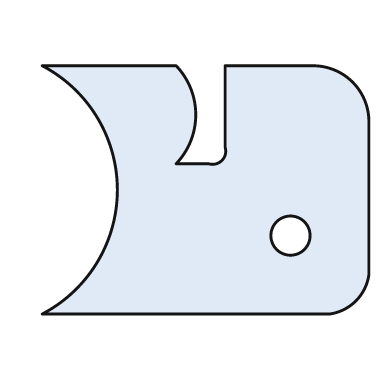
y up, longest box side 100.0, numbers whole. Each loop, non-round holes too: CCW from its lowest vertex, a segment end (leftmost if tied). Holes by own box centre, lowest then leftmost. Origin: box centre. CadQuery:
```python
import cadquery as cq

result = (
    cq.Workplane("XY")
    .moveTo(-50.0, -38.0)
    .lineTo(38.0, -38.0)
    .threePointArc((46.0, -34.0), (50.0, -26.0))
    .lineTo(50.0, 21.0)
    .threePointArc((45.0, 33.0), (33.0, 38.0))
    .lineTo(6.0, 38.0)
    .lineTo(6.0, 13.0)
    .threePointArc((5.0, 9.0), (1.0, 8.0))
    .lineTo(-9.0, 8.0)
    .threePointArc((-3.0, 23.0), (-9.0, 38.0))
    .lineTo(-50.0, 38.0)
    .threePointArc((-27.0, 0.0), (-50.0, -38.0))
    .close()
    .moveTo(26.0, -14.0)
    .circle(6.0)
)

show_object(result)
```